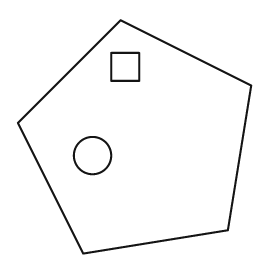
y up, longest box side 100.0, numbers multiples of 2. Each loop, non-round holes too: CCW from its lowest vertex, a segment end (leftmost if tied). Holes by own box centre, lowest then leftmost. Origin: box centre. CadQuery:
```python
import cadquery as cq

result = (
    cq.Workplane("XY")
    .moveTo(-22.0, -50.0)
    .lineTo(40.0, -40.0)
    .lineTo(50.0, 22.0)
    .lineTo(-6.0, 50.0)
    .lineTo(-50.0, 6.0)
    .close()
    .moveTo(-18.0, -8.0)
    .circle(8.0)
    .moveTo(-10.0, 24.0)
    .lineTo(2.0, 24.0)
    .lineTo(2.0, 36.0)
    .lineTo(-10.0, 36.0)
    .close()
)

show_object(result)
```